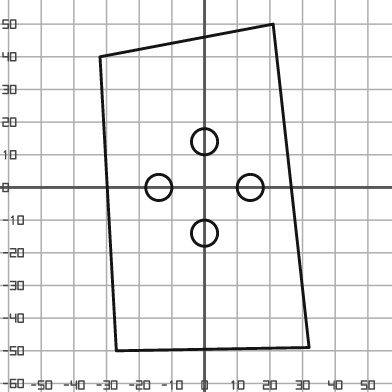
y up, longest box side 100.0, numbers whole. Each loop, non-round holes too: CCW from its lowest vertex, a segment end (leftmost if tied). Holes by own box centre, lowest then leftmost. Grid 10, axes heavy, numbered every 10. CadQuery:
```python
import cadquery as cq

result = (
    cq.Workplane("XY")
    .moveTo(-27.0, -50.0)
    .lineTo(32.0, -49.0)
    .lineTo(21.0, 50.0)
    .lineTo(-32.0, 40.0)
    .close()
    .moveTo(0.0, -14.0)
    .circle(4.0)
    .moveTo(-14.0, 0.0)
    .circle(4.0)
    .moveTo(14.0, 0.0)
    .circle(4.0)
    .moveTo(0.0, 14.0)
    .circle(4.0)
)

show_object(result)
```